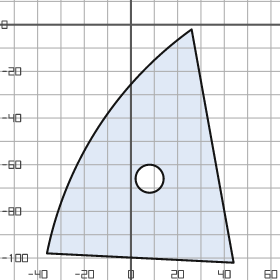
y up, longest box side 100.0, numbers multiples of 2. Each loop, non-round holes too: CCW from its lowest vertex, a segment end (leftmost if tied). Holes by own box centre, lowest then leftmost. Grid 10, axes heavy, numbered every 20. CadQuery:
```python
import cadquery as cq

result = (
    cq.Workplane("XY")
    .moveTo(44.0, -102.0)
    .lineTo(26.0, -2.0)
    .threePointArc((-14.0, -44.0), (-36.0, -98.0))
    .close()
    .moveTo(8.0, -66.0)
    .circle(6.0)
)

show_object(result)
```